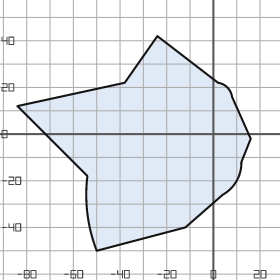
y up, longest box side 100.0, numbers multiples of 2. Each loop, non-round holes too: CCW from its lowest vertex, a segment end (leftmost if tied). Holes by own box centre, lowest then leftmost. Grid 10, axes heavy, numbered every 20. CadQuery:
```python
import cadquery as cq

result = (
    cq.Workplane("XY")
    .moveTo(-50.0, -50.0)
    .lineTo(-12.0, -40.0)
    .lineTo(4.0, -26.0)
    .threePointArc((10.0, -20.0), (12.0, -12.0))
    .lineTo(16.0, -2.0)
    .lineTo(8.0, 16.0)
    .threePointArc((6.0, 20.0), (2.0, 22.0))
    .lineTo(-24.0, 42.0)
    .lineTo(-38.0, 22.0)
    .lineTo(-84.0, 12.0)
    .lineTo(-54.0, -18.0)
    .threePointArc((-54.0, -34.0), (-50.0, -50.0))
    .close()
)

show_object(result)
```